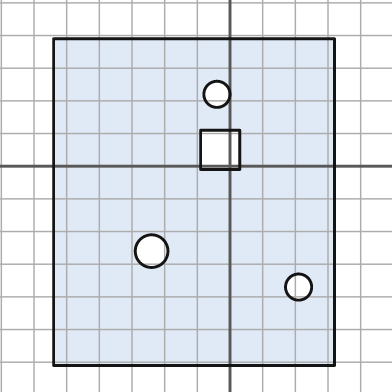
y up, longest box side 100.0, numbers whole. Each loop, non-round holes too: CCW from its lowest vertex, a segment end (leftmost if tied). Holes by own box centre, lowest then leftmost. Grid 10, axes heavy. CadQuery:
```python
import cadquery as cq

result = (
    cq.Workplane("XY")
    .moveTo(-54.0, -61.0)
    .lineTo(32.0, -61.0)
    .lineTo(32.0, 39.0)
    .lineTo(-54.0, 39.0)
    .close()
    .moveTo(21.0, -37.0)
    .circle(4.0)
    .moveTo(-24.0, -26.0)
    .circle(5.0)
    .moveTo(-9.0, -1.0)
    .lineTo(3.0, -1.0)
    .lineTo(3.0, 11.0)
    .lineTo(-9.0, 11.0)
    .close()
    .moveTo(-4.0, 22.0)
    .circle(4.0)
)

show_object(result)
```